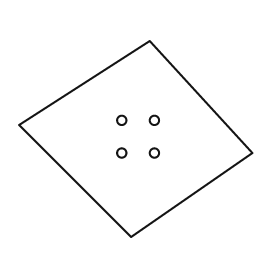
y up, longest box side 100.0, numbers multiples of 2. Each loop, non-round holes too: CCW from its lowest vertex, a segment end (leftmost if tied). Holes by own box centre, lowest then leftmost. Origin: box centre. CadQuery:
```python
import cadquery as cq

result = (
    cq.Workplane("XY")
    .moveTo(-2.0, -42.0)
    .lineTo(50.0, -6.0)
    .lineTo(6.0, 42.0)
    .lineTo(-50.0, 6.0)
    .close()
    .moveTo(-6.0, -6.0)
    .circle(2.0)
    .moveTo(8.0, -6.0)
    .circle(2.0)
    .moveTo(-6.0, 8.0)
    .circle(2.0)
    .moveTo(8.0, 8.0)
    .circle(2.0)
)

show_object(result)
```